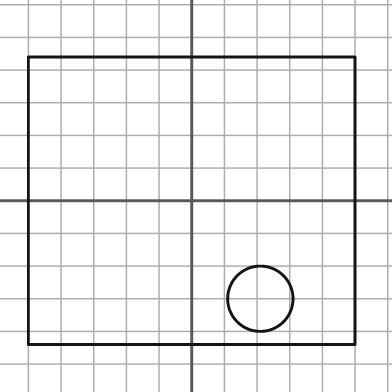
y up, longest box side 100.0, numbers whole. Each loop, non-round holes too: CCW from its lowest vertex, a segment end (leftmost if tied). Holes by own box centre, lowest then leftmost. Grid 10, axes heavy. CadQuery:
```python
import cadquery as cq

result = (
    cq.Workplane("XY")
    .moveTo(-50.0, -44.0)
    .lineTo(50.0, -44.0)
    .lineTo(50.0, 44.0)
    .lineTo(-50.0, 44.0)
    .close()
    .moveTo(21.0, -30.0)
    .circle(10.0)
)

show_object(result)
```